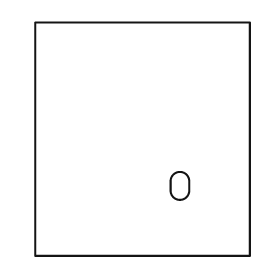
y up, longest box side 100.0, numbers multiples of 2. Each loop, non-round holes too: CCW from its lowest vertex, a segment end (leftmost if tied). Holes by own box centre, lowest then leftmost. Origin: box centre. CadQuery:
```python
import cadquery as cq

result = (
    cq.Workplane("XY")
    .moveTo(-46.0, -50.0)
    .lineTo(46.0, -50.0)
    .lineTo(46.0, 50.0)
    .lineTo(-46.0, 50.0)
    .close()
    .moveTo(12.0, -22.0)
    .threePointArc((16.0, -26.0), (20.0, -22.0))
    .lineTo(20.0, -18.0)
    .threePointArc((16.0, -14.0), (12.0, -18.0))
    .close()
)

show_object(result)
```